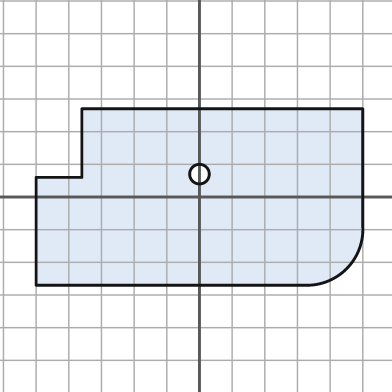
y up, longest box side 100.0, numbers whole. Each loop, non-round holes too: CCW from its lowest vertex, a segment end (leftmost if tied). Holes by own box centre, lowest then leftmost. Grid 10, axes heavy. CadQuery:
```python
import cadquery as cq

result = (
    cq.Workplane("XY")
    .moveTo(-50.0, -27.0)
    .lineTo(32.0, -27.0)
    .threePointArc((45.0, -22.0), (50.0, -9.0))
    .lineTo(50.0, 27.0)
    .lineTo(-36.0, 27.0)
    .lineTo(-36.0, 6.0)
    .lineTo(-50.0, 6.0)
    .close()
    .moveTo(0.0, 7.0)
    .circle(3.0)
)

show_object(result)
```